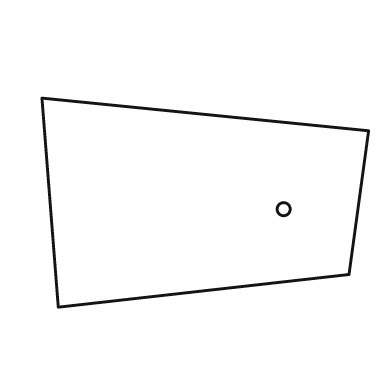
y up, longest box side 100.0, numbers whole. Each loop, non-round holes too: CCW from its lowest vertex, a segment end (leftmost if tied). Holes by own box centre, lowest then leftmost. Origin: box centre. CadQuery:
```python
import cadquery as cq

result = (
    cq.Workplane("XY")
    .moveTo(-45.0, -32.0)
    .lineTo(44.0, -22.0)
    .lineTo(50.0, 22.0)
    .lineTo(-50.0, 32.0)
    .close()
    .moveTo(24.0, -2.0)
    .circle(2.0)
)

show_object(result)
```